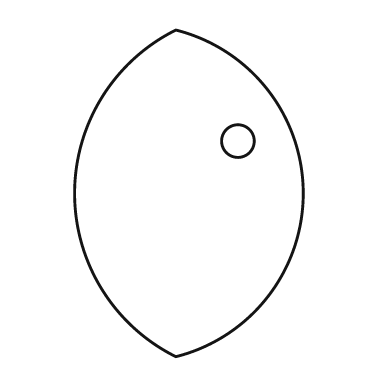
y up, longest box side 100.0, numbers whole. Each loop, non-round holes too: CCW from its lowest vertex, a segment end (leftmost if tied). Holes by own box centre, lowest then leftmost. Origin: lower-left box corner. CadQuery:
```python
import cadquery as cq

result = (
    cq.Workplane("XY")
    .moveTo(31.0, 0.0)
    .threePointArc((70.0, 50.0), (31.0, 100.0))
    .threePointArc((0.0, 50.0), (31.0, 0.0))
    .close()
    .moveTo(50.0, 66.0)
    .circle(5.0)
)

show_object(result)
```